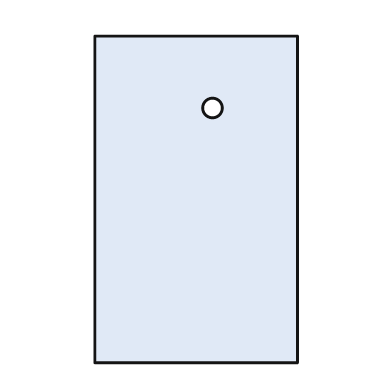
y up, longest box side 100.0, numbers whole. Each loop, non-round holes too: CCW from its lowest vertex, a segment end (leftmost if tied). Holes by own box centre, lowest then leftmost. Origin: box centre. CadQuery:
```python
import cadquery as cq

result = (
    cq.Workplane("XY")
    .moveTo(-31.0, -50.0)
    .lineTo(31.0, -50.0)
    .lineTo(31.0, 50.0)
    .lineTo(-31.0, 50.0)
    .close()
    .moveTo(5.0, 28.0)
    .circle(3.0)
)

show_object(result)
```